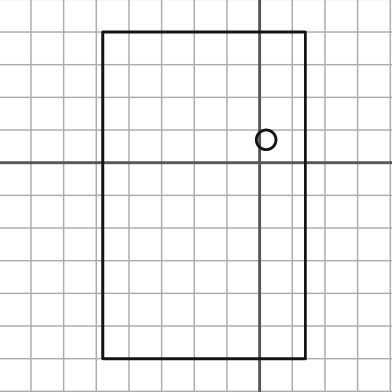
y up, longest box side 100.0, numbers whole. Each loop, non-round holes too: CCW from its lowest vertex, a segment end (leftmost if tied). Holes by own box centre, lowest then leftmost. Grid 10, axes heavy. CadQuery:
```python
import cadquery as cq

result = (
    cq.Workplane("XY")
    .moveTo(-48.0, -60.0)
    .lineTo(14.0, -60.0)
    .lineTo(14.0, 40.0)
    .lineTo(-48.0, 40.0)
    .close()
    .moveTo(2.0, 7.0)
    .circle(3.0)
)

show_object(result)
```